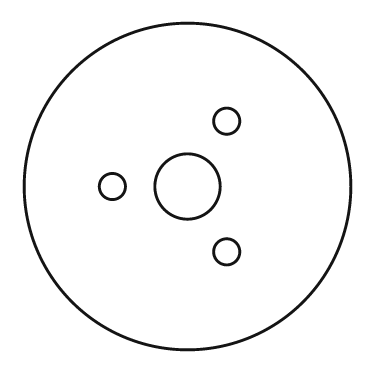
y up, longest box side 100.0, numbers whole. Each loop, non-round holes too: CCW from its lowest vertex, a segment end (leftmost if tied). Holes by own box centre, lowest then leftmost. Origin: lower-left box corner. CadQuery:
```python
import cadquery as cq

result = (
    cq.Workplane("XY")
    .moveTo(50.0, 50.0)
    .circle(50.0)
    .moveTo(62.0, 30.0)
    .circle(4.0)
    .moveTo(27.0, 50.0)
    .circle(4.0)
    .moveTo(50.0, 50.0)
    .circle(10.0)
    .moveTo(62.0, 70.0)
    .circle(4.0)
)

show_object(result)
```